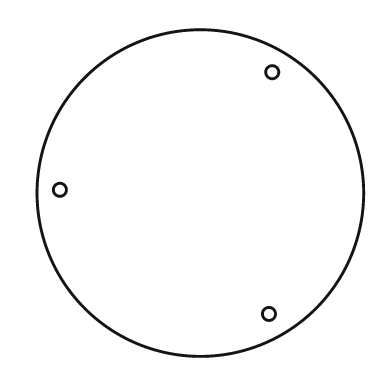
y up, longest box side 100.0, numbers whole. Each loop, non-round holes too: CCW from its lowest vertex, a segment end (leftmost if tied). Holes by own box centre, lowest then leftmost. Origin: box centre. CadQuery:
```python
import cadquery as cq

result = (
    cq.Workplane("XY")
    .moveTo(0.0, 0.0)
    .circle(50.0)
    .moveTo(21.0, -37.0)
    .circle(2.0)
    .moveTo(-43.0, 1.0)
    .circle(2.0)
    .moveTo(22.0, 37.0)
    .circle(2.0)
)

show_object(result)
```